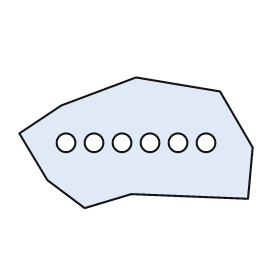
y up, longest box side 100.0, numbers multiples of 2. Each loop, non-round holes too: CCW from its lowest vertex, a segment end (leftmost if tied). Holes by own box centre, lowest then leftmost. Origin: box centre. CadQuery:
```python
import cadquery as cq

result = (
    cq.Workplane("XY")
    .moveTo(-22.0, -28.0)
    .lineTo(-2.0, -22.0)
    .lineTo(48.0, -24.0)
    .lineTo(50.0, -2.0)
    .lineTo(36.0, 22.0)
    .lineTo(0.0, 28.0)
    .lineTo(-32.0, 16.0)
    .lineTo(-50.0, 4.0)
    .lineTo(-38.0, -16.0)
    .close()
    .moveTo(-30.0, 0.0)
    .circle(4.0)
    .moveTo(-18.0, 0.0)
    .circle(4.0)
    .moveTo(-6.0, 0.0)
    .circle(4.0)
    .moveTo(6.0, 0.0)
    .circle(4.0)
    .moveTo(18.0, 0.0)
    .circle(4.0)
    .moveTo(30.0, 0.0)
    .circle(4.0)
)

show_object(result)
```